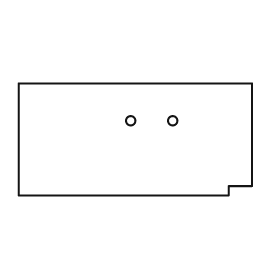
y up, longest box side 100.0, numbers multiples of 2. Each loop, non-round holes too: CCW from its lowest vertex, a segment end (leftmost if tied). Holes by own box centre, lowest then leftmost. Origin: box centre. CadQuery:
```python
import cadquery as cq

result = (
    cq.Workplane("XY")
    .moveTo(-50.0, -24.0)
    .lineTo(40.0, -24.0)
    .lineTo(40.0, -20.0)
    .lineTo(50.0, -20.0)
    .lineTo(50.0, 24.0)
    .lineTo(-50.0, 24.0)
    .close()
    .moveTo(-2.0, 8.0)
    .circle(2.0)
    .moveTo(16.0, 8.0)
    .circle(2.0)
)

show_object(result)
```